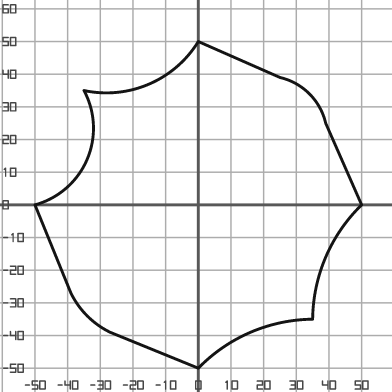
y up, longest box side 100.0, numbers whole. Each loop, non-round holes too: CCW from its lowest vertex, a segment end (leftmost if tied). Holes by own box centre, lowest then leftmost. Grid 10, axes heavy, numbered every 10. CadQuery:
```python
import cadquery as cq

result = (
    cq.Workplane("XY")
    .moveTo(0.0, -50.0)
    .threePointArc((16.0, -39.0), (35.0, -35.0))
    .threePointArc((39.0, -16.0), (50.0, 0.0))
    .lineTo(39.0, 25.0)
    .threePointArc((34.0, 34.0), (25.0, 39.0))
    .lineTo(0.0, 50.0)
    .threePointArc((-15.0, 37.0), (-35.0, 35.0))
    .threePointArc((-34.0, 14.0), (-50.0, 0.0))
    .lineTo(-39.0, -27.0)
    .threePointArc((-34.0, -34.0), (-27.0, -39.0))
    .close()
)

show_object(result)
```